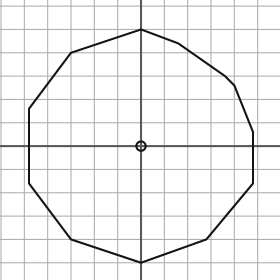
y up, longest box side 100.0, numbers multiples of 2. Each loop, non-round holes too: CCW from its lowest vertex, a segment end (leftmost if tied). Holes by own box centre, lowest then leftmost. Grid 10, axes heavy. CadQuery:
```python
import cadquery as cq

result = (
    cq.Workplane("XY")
    .moveTo(0.0, -50.0)
    .lineTo(28.0, -40.0)
    .lineTo(48.0, -16.0)
    .lineTo(48.0, 6.0)
    .lineTo(40.0, 26.0)
    .lineTo(36.0, 30.0)
    .lineTo(16.0, 44.0)
    .lineTo(0.0, 50.0)
    .lineTo(-30.0, 40.0)
    .lineTo(-48.0, 16.0)
    .lineTo(-48.0, -16.0)
    .lineTo(-30.0, -40.0)
    .close()
    .moveTo(0.0, 0.0)
    .circle(2.0)
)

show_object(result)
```